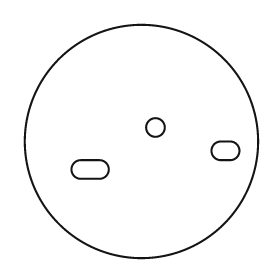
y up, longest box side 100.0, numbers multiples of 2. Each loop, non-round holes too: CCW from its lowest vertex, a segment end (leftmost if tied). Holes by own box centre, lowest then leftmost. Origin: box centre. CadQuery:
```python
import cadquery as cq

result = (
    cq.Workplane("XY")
    .moveTo(0.0, 0.0)
    .circle(50.0)
    .moveTo(-26.0, -16.0)
    .lineTo(-18.0, -16.0)
    .threePointArc((-14.0, -12.0), (-18.0, -8.0))
    .lineTo(-26.0, -8.0)
    .threePointArc((-30.0, -12.0), (-26.0, -16.0))
    .close()
    .moveTo(34.0, -8.0)
    .lineTo(38.0, -8.0)
    .threePointArc((42.0, -4.0), (38.0, 0.0))
    .lineTo(34.0, 0.0)
    .threePointArc((30.0, -4.0), (34.0, -8.0))
    .close()
    .moveTo(6.0, 6.0)
    .circle(4.0)
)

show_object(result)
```